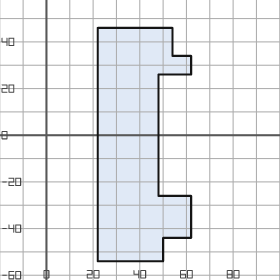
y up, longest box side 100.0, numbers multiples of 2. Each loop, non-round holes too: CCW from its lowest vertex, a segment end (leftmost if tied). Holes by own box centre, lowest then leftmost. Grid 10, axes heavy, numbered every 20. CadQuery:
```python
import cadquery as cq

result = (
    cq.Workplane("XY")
    .moveTo(22.0, -54.0)
    .lineTo(50.0, -54.0)
    .lineTo(50.0, -44.0)
    .lineTo(62.0, -44.0)
    .lineTo(62.0, -26.0)
    .lineTo(48.0, -26.0)
    .lineTo(48.0, 26.0)
    .lineTo(62.0, 26.0)
    .lineTo(62.0, 34.0)
    .lineTo(54.0, 34.0)
    .lineTo(54.0, 46.0)
    .lineTo(22.0, 46.0)
    .close()
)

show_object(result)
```